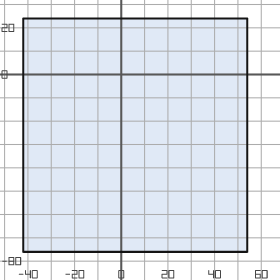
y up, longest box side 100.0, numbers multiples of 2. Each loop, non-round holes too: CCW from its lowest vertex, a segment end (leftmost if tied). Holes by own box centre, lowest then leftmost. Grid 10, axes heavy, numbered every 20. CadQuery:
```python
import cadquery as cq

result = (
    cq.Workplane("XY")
    .moveTo(-42.0, -76.0)
    .lineTo(54.0, -76.0)
    .lineTo(54.0, 24.0)
    .lineTo(-42.0, 24.0)
    .close()
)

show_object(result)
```